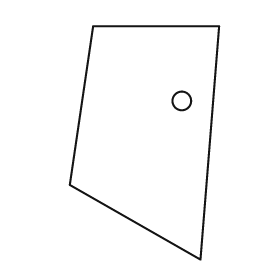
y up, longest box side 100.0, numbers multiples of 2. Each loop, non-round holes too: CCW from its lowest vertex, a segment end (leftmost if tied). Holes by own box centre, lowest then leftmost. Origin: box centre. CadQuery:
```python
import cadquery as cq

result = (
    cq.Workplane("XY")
    .moveTo(24.0, -50.0)
    .lineTo(32.0, 50.0)
    .lineTo(-22.0, 50.0)
    .lineTo(-32.0, -18.0)
    .close()
    .moveTo(16.0, 18.0)
    .circle(4.0)
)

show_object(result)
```